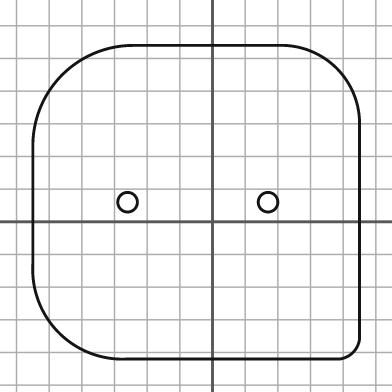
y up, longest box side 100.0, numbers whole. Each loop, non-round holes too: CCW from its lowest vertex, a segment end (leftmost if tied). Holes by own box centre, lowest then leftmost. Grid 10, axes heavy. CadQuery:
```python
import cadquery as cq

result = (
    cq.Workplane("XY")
    .moveTo(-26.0, -42.0)
    .lineTo(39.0, -42.0)
    .threePointArc((43.0, -40.0), (45.0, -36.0))
    .lineTo(45.0, 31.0)
    .threePointArc((38.0, 47.0), (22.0, 54.0))
    .lineTo(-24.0, 54.0)
    .threePointArc((-46.0, 45.0), (-55.0, 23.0))
    .lineTo(-55.0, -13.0)
    .threePointArc((-47.0, -34.0), (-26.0, -42.0))
    .close()
    .moveTo(-26.0, 6.0)
    .circle(3.0)
    .moveTo(17.0, 6.0)
    .circle(3.0)
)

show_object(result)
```